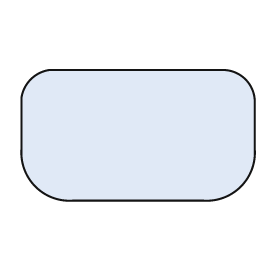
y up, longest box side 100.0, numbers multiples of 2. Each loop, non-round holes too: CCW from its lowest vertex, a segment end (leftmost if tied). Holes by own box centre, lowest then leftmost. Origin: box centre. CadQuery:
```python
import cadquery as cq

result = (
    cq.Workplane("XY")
    .moveTo(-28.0, -28.0)
    .lineTo(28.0, -28.0)
    .threePointArc((44.0, -22.0), (50.0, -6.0))
    .lineTo(50.0, 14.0)
    .threePointArc((46.0, 24.0), (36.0, 28.0))
    .lineTo(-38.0, 28.0)
    .threePointArc((-46.0, 24.0), (-50.0, 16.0))
    .lineTo(-50.0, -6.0)
    .threePointArc((-44.0, -22.0), (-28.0, -28.0))
    .close()
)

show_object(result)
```